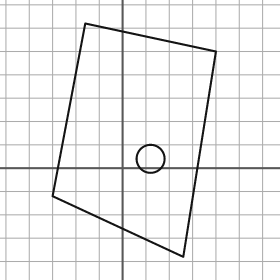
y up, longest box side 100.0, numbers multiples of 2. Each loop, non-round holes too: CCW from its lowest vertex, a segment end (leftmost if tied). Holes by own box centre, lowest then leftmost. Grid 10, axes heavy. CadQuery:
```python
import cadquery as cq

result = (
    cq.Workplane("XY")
    .moveTo(26.0, -38.0)
    .lineTo(40.0, 50.0)
    .lineTo(-16.0, 62.0)
    .lineTo(-30.0, -12.0)
    .close()
    .moveTo(12.0, 4.0)
    .circle(6.0)
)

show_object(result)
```